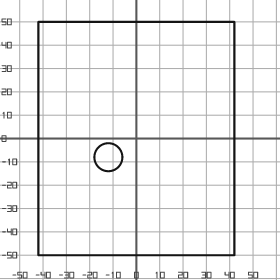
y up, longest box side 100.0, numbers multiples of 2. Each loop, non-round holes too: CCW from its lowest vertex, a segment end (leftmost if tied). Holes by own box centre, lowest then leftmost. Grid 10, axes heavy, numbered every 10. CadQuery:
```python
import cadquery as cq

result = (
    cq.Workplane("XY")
    .moveTo(-42.0, -50.0)
    .lineTo(42.0, -50.0)
    .lineTo(42.0, 50.0)
    .lineTo(-42.0, 50.0)
    .close()
    .moveTo(-12.0, -8.0)
    .circle(6.0)
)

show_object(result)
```